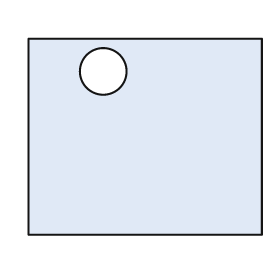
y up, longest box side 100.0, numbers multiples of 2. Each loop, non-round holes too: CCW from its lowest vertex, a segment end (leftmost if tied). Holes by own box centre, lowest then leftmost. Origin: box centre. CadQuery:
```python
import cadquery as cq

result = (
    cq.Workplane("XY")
    .moveTo(-50.0, -42.0)
    .lineTo(50.0, -42.0)
    .lineTo(50.0, 42.0)
    .lineTo(-50.0, 42.0)
    .close()
    .moveTo(-18.0, 28.0)
    .circle(10.0)
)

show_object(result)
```